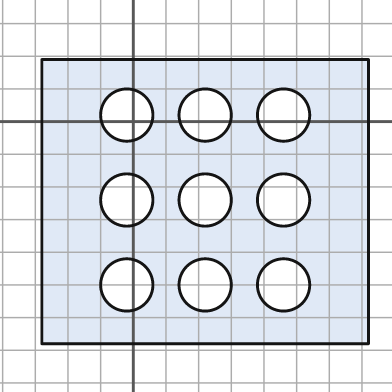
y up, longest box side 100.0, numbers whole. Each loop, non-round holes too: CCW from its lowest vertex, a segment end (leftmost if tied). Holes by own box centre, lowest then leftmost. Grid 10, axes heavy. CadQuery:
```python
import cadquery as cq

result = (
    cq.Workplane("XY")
    .moveTo(-28.0, -68.0)
    .lineTo(72.0, -68.0)
    .lineTo(72.0, 19.0)
    .lineTo(-28.0, 19.0)
    .close()
    .moveTo(-2.0, -50.0)
    .circle(8.0)
    .moveTo(22.0, -50.0)
    .circle(8.0)
    .moveTo(46.0, -50.0)
    .circle(8.0)
    .moveTo(-2.0, -24.0)
    .circle(8.0)
    .moveTo(22.0, -24.0)
    .circle(8.0)
    .moveTo(46.0, -24.0)
    .circle(8.0)
    .moveTo(-2.0, 2.0)
    .circle(8.0)
    .moveTo(22.0, 2.0)
    .circle(8.0)
    .moveTo(46.0, 2.0)
    .circle(8.0)
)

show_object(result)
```